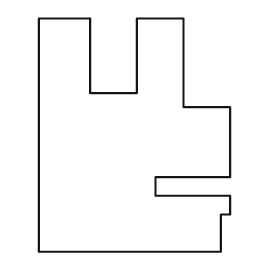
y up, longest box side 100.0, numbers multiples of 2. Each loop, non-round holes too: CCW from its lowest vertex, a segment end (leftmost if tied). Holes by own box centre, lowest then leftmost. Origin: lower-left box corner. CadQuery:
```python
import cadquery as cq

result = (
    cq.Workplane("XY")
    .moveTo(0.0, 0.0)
    .lineTo(78.0, 0.0)
    .lineTo(78.0, 16.0)
    .lineTo(82.0, 16.0)
    .lineTo(82.0, 24.0)
    .lineTo(50.0, 24.0)
    .lineTo(50.0, 32.0)
    .lineTo(82.0, 32.0)
    .lineTo(82.0, 62.0)
    .lineTo(62.0, 62.0)
    .lineTo(62.0, 100.0)
    .lineTo(42.0, 100.0)
    .lineTo(42.0, 68.0)
    .lineTo(22.0, 68.0)
    .lineTo(22.0, 100.0)
    .lineTo(0.0, 100.0)
    .close()
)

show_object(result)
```